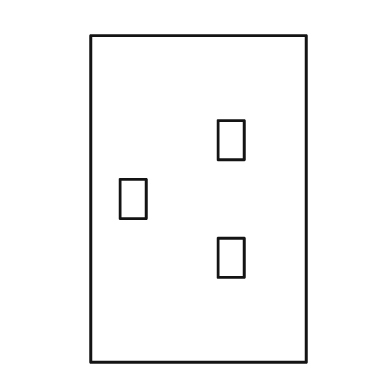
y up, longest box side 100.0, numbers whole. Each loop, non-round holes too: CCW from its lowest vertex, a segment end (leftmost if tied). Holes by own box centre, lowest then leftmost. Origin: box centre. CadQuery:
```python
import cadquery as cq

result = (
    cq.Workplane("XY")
    .moveTo(-33.0, -50.0)
    .lineTo(33.0, -50.0)
    .lineTo(33.0, 50.0)
    .lineTo(-33.0, 50.0)
    .close()
    .moveTo(6.0, -24.0)
    .lineTo(14.0, -24.0)
    .lineTo(14.0, -12.0)
    .lineTo(6.0, -12.0)
    .close()
    .moveTo(-24.0, -6.0)
    .lineTo(-16.0, -6.0)
    .lineTo(-16.0, 6.0)
    .lineTo(-24.0, 6.0)
    .close()
    .moveTo(6.0, 12.0)
    .lineTo(14.0, 12.0)
    .lineTo(14.0, 24.0)
    .lineTo(6.0, 24.0)
    .close()
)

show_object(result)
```